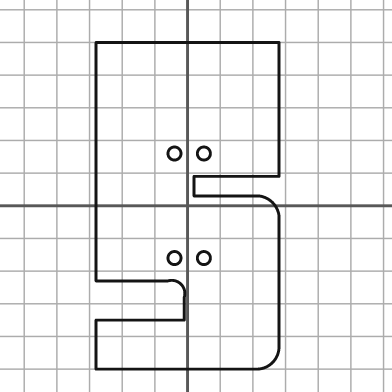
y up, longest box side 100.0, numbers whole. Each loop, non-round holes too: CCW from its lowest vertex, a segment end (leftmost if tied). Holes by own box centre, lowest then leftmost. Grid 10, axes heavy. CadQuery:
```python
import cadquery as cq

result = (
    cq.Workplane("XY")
    .moveTo(-28.0, -50.0)
    .lineTo(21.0, -50.0)
    .threePointArc((26.0, -48.0), (28.0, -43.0))
    .lineTo(28.0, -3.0)
    .threePointArc((26.0, 1.0), (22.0, 3.0))
    .lineTo(2.0, 3.0)
    .lineTo(2.0, 9.0)
    .lineTo(28.0, 9.0)
    .lineTo(28.0, 50.0)
    .lineTo(-28.0, 50.0)
    .lineTo(-28.0, -23.0)
    .lineTo(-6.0, -23.0)
    .threePointArc((-2.0, -24.0), (-1.0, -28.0))
    .lineTo(-1.0, -35.0)
    .lineTo(-28.0, -35.0)
    .close()
    .moveTo(-4.0, -16.0)
    .circle(2.0)
    .moveTo(5.0, -16.0)
    .circle(2.0)
    .moveTo(-4.0, 16.0)
    .circle(2.0)
    .moveTo(5.0, 16.0)
    .circle(2.0)
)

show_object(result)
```